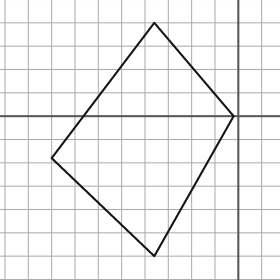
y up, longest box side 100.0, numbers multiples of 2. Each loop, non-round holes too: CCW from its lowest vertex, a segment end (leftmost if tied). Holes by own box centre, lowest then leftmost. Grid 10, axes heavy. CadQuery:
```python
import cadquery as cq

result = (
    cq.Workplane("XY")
    .moveTo(-36.0, -60.0)
    .lineTo(-2.0, 0.0)
    .lineTo(-36.0, 40.0)
    .lineTo(-80.0, -18.0)
    .close()
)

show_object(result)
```